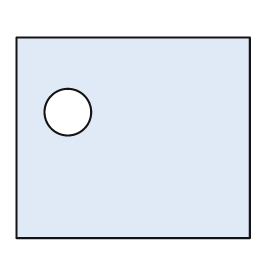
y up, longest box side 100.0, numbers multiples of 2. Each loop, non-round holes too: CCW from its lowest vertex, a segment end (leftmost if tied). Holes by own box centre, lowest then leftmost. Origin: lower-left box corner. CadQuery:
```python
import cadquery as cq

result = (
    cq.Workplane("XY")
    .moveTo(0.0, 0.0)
    .lineTo(100.0, 0.0)
    .lineTo(100.0, 86.0)
    .lineTo(0.0, 86.0)
    .close()
    .moveTo(22.0, 54.0)
    .circle(10.0)
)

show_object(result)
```